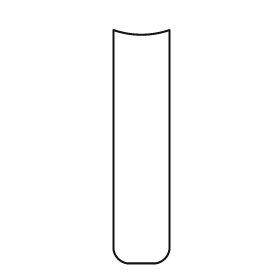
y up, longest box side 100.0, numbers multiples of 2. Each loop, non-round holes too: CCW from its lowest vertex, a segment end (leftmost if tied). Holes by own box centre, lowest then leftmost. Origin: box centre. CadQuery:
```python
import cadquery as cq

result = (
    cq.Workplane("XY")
    .moveTo(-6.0, -50.0)
    .lineTo(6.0, -50.0)
    .threePointArc((10.0, -48.0), (12.0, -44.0))
    .lineTo(12.0, 50.0)
    .threePointArc((0.0, 48.0), (-12.0, 50.0))
    .lineTo(-12.0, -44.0)
    .threePointArc((-10.0, -48.0), (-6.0, -50.0))
    .close()
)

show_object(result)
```